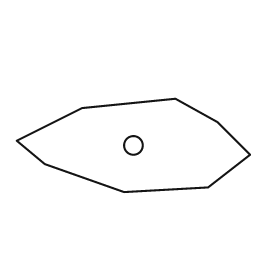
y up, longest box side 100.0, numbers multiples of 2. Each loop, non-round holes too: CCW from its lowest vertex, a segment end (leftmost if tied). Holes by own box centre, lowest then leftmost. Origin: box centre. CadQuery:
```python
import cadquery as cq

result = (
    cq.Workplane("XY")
    .moveTo(-4.0, -20.0)
    .lineTo(32.0, -18.0)
    .lineTo(50.0, -4.0)
    .lineTo(36.0, 10.0)
    .lineTo(18.0, 20.0)
    .lineTo(-22.0, 16.0)
    .lineTo(-50.0, 2.0)
    .lineTo(-38.0, -8.0)
    .close()
    .moveTo(0.0, 0.0)
    .circle(4.0)
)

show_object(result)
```